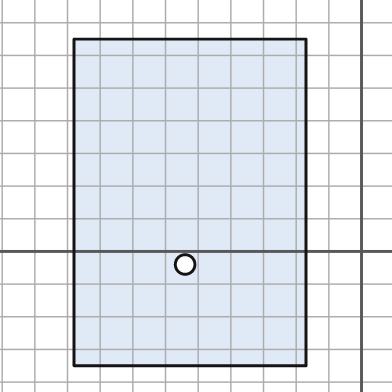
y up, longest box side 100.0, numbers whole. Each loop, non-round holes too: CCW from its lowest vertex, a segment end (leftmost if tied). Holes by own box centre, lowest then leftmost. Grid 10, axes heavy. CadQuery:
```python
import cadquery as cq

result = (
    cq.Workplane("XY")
    .moveTo(-88.0, -35.0)
    .lineTo(-17.0, -35.0)
    .lineTo(-17.0, 65.0)
    .lineTo(-88.0, 65.0)
    .close()
    .moveTo(-54.0, -4.0)
    .circle(3.0)
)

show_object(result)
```